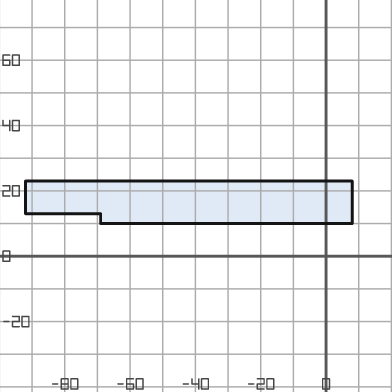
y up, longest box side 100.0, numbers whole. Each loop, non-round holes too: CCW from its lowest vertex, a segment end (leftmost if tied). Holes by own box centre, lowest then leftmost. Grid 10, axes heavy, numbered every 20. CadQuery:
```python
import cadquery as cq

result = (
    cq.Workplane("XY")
    .moveTo(-69.0, 10.0)
    .lineTo(8.0, 10.0)
    .lineTo(8.0, 23.0)
    .lineTo(-92.0, 23.0)
    .lineTo(-92.0, 13.0)
    .lineTo(-69.0, 13.0)
    .close()
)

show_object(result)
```